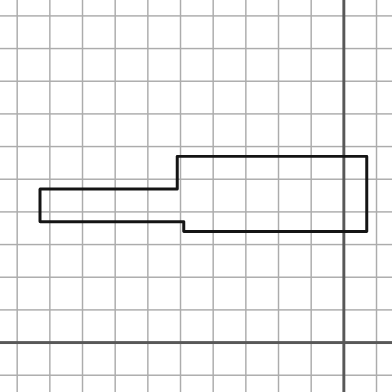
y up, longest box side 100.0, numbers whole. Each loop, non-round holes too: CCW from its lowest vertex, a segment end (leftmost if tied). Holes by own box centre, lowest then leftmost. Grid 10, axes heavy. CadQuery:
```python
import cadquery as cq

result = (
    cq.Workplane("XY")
    .moveTo(-49.0, 34.0)
    .lineTo(7.0, 34.0)
    .lineTo(7.0, 57.0)
    .lineTo(-51.0, 57.0)
    .lineTo(-51.0, 47.0)
    .lineTo(-93.0, 47.0)
    .lineTo(-93.0, 37.0)
    .lineTo(-49.0, 37.0)
    .close()
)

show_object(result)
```